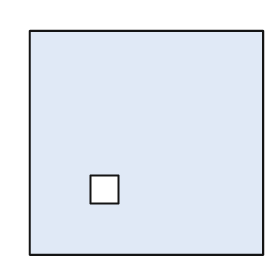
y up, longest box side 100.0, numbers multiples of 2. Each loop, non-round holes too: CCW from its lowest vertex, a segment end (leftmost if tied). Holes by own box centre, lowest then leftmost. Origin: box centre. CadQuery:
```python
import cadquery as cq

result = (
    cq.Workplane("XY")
    .moveTo(-50.0, -48.0)
    .lineTo(50.0, -48.0)
    .lineTo(50.0, 48.0)
    .lineTo(-50.0, 48.0)
    .close()
    .moveTo(-24.0, -26.0)
    .lineTo(-12.0, -26.0)
    .lineTo(-12.0, -14.0)
    .lineTo(-24.0, -14.0)
    .close()
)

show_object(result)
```